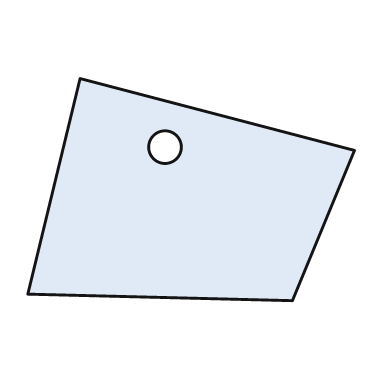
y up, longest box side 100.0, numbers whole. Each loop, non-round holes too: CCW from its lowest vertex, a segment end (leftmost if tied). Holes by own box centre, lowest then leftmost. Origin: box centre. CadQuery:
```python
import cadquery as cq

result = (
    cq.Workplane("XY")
    .moveTo(31.0, -34.0)
    .lineTo(50.0, 12.0)
    .lineTo(-34.0, 34.0)
    .lineTo(-50.0, -32.0)
    .close()
    .moveTo(-8.0, 13.0)
    .circle(5.0)
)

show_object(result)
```